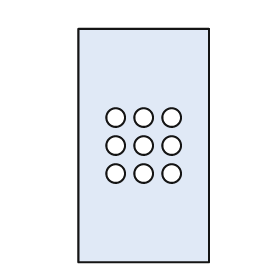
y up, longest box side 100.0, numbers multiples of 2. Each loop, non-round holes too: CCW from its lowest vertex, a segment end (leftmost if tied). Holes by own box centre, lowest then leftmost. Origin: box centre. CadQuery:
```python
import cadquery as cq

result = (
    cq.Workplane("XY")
    .moveTo(-28.0, -50.0)
    .lineTo(28.0, -50.0)
    .lineTo(28.0, 50.0)
    .lineTo(-28.0, 50.0)
    .close()
    .moveTo(-12.0, -12.0)
    .circle(4.0)
    .moveTo(0.0, -12.0)
    .circle(4.0)
    .moveTo(12.0, -12.0)
    .circle(4.0)
    .moveTo(-12.0, 0.0)
    .circle(4.0)
    .moveTo(0.0, 0.0)
    .circle(4.0)
    .moveTo(12.0, 0.0)
    .circle(4.0)
    .moveTo(-12.0, 12.0)
    .circle(4.0)
    .moveTo(0.0, 12.0)
    .circle(4.0)
    .moveTo(12.0, 12.0)
    .circle(4.0)
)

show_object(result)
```